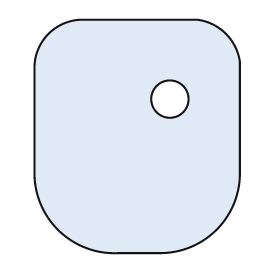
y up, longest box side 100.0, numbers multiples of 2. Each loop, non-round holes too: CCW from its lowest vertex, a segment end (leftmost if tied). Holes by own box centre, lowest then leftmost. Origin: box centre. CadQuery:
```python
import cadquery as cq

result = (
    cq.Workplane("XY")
    .moveTo(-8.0, -50.0)
    .lineTo(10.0, -50.0)
    .threePointArc((34.0, -40.0), (44.0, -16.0))
    .lineTo(44.0, 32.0)
    .threePointArc((38.0, 44.0), (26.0, 50.0))
    .lineTo(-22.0, 50.0)
    .threePointArc((-38.0, 44.0), (-44.0, 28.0))
    .lineTo(-44.0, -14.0)
    .threePointArc((-34.0, -40.0), (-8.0, -50.0))
    .close()
    .moveTo(14.0, 16.0)
    .circle(8.0)
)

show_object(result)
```